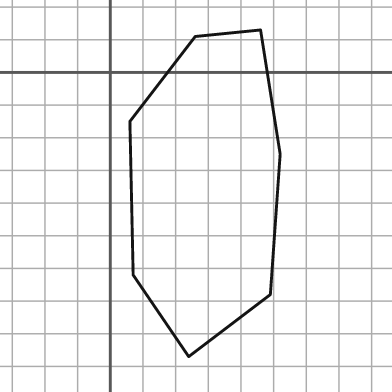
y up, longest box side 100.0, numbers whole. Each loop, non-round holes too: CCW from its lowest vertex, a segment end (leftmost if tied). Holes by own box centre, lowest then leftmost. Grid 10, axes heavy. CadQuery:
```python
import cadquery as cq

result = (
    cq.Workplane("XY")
    .moveTo(24.0, -87.0)
    .lineTo(49.0, -68.0)
    .lineTo(52.0, -25.0)
    .lineTo(46.0, 13.0)
    .lineTo(26.0, 11.0)
    .lineTo(6.0, -15.0)
    .lineTo(7.0, -62.0)
    .close()
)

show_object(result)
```